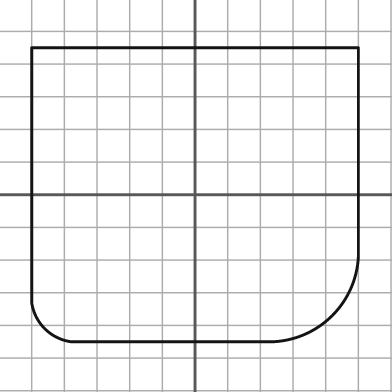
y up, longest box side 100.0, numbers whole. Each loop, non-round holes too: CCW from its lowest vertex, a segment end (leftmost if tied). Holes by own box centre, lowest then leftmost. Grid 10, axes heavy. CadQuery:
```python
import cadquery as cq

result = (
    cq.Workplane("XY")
    .moveTo(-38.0, -45.0)
    .lineTo(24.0, -45.0)
    .threePointArc((42.0, -37.0), (50.0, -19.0))
    .lineTo(50.0, 45.0)
    .lineTo(-50.0, 45.0)
    .lineTo(-50.0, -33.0)
    .threePointArc((-46.0, -41.0), (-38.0, -45.0))
    .close()
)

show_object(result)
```